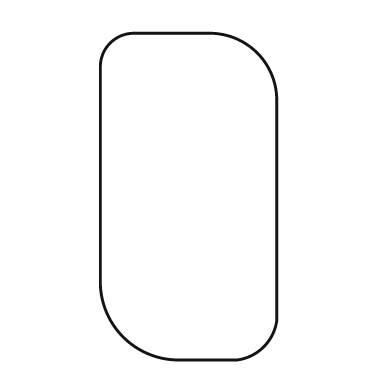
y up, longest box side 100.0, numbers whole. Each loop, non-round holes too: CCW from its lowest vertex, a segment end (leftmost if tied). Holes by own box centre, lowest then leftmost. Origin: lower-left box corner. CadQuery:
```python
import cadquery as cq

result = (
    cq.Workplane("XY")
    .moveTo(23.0, 0.0)
    .lineTo(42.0, 0.0)
    .threePointArc((50.0, 4.0), (54.0, 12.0))
    .lineTo(54.0, 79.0)
    .threePointArc((48.0, 94.0), (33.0, 100.0))
    .lineTo(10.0, 100.0)
    .threePointArc((3.0, 97.0), (0.0, 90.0))
    .lineTo(0.0, 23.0)
    .threePointArc((7.0, 7.0), (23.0, 0.0))
    .close()
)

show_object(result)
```